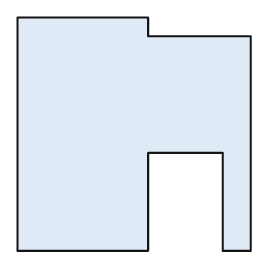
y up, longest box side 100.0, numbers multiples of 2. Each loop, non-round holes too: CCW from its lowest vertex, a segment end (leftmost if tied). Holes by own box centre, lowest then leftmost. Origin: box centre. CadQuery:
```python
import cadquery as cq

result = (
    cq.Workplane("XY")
    .moveTo(-50.0, -50.0)
    .lineTo(6.0, -50.0)
    .lineTo(6.0, -8.0)
    .lineTo(38.0, -8.0)
    .lineTo(38.0, -50.0)
    .lineTo(50.0, -50.0)
    .lineTo(50.0, 42.0)
    .lineTo(6.0, 42.0)
    .lineTo(6.0, 50.0)
    .lineTo(-50.0, 50.0)
    .close()
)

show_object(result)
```